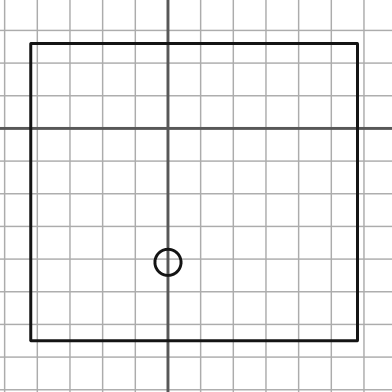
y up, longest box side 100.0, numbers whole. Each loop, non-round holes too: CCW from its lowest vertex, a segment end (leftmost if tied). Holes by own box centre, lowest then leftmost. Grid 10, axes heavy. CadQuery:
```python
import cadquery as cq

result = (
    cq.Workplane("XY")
    .moveTo(-42.0, -65.0)
    .lineTo(58.0, -65.0)
    .lineTo(58.0, 26.0)
    .lineTo(-42.0, 26.0)
    .close()
    .moveTo(0.0, -41.0)
    .circle(4.0)
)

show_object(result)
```